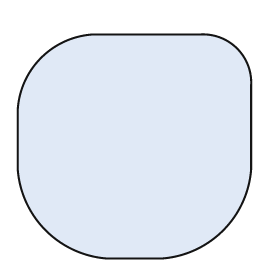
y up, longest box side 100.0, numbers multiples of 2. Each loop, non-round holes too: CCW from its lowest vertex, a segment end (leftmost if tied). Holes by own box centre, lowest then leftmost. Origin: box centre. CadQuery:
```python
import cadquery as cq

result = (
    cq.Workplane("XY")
    .moveTo(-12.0, -48.0)
    .lineTo(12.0, -48.0)
    .threePointArc((38.0, -36.0), (50.0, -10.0))
    .lineTo(50.0, 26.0)
    .threePointArc((44.0, 42.0), (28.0, 48.0))
    .lineTo(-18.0, 48.0)
    .threePointArc((-40.0, 38.0), (-50.0, 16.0))
    .lineTo(-50.0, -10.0)
    .threePointArc((-38.0, -36.0), (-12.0, -48.0))
    .close()
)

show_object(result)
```